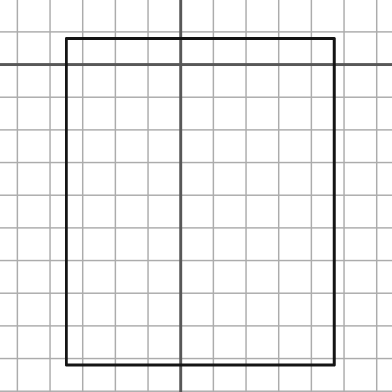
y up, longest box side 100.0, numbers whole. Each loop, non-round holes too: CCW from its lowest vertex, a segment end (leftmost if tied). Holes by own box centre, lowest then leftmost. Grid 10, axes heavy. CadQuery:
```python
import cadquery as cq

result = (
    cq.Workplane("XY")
    .moveTo(-35.0, -92.0)
    .lineTo(47.0, -92.0)
    .lineTo(47.0, 8.0)
    .lineTo(-35.0, 8.0)
    .close()
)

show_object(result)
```